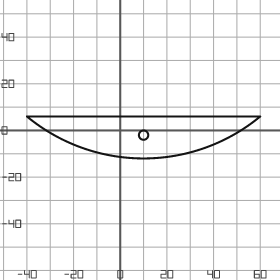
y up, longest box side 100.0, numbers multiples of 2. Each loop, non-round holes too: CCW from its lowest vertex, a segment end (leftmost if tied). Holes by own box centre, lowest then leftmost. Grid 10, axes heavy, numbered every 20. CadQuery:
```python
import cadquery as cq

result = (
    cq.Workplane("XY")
    .moveTo(-40.0, 6.0)
    .threePointArc((10.0, -12.0), (60.0, 6.0))
    .close()
    .moveTo(10.0, -2.0)
    .circle(2.0)
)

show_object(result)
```